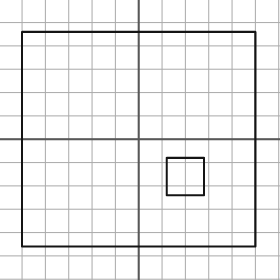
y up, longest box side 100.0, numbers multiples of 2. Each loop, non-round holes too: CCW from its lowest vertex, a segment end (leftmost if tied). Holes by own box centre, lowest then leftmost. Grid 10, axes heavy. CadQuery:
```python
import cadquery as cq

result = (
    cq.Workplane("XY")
    .moveTo(-50.0, -46.0)
    .lineTo(50.0, -46.0)
    .lineTo(50.0, 46.0)
    .lineTo(-50.0, 46.0)
    .close()
    .moveTo(12.0, -24.0)
    .lineTo(28.0, -24.0)
    .lineTo(28.0, -8.0)
    .lineTo(12.0, -8.0)
    .close()
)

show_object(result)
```